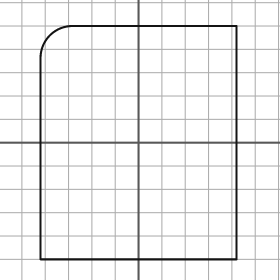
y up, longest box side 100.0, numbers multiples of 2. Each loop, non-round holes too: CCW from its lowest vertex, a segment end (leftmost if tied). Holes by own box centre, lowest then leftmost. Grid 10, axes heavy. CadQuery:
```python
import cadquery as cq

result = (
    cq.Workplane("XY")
    .moveTo(-42.0, -50.0)
    .lineTo(42.0, -50.0)
    .lineTo(42.0, 50.0)
    .lineTo(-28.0, 50.0)
    .threePointArc((-38.0, 46.0), (-42.0, 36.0))
    .close()
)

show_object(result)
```